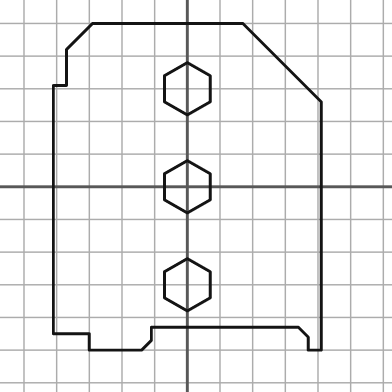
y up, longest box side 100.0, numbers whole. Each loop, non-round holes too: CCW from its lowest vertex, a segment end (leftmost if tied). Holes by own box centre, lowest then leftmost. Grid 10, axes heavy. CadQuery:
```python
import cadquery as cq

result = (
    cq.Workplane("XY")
    .moveTo(-30.0, -50.0)
    .lineTo(-14.0, -50.0)
    .lineTo(-11.0, -47.0)
    .lineTo(-11.0, -43.0)
    .lineTo(34.0, -43.0)
    .lineTo(37.0, -46.0)
    .lineTo(37.0, -50.0)
    .lineTo(41.0, -50.0)
    .lineTo(41.0, 26.0)
    .lineTo(17.0, 50.0)
    .lineTo(-29.0, 50.0)
    .lineTo(-37.0, 42.0)
    .lineTo(-37.0, 31.0)
    .lineTo(-41.0, 31.0)
    .lineTo(-41.0, -45.0)
    .lineTo(-30.0, -45.0)
    .close()
    .moveTo(0.0, -38.0)
    .lineTo(7.0, -34.0)
    .lineTo(7.0, -26.0)
    .lineTo(0.0, -22.0)
    .lineTo(-7.0, -26.0)
    .lineTo(-7.0, -34.0)
    .close()
    .moveTo(0.0, -8.0)
    .lineTo(7.0, -4.0)
    .lineTo(7.0, 4.0)
    .lineTo(0.0, 8.0)
    .lineTo(-7.0, 4.0)
    .lineTo(-7.0, -4.0)
    .close()
    .moveTo(0.0, 22.0)
    .lineTo(7.0, 26.0)
    .lineTo(7.0, 34.0)
    .lineTo(0.0, 38.0)
    .lineTo(-7.0, 34.0)
    .lineTo(-7.0, 26.0)
    .close()
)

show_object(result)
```